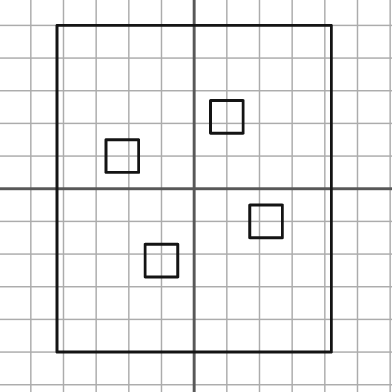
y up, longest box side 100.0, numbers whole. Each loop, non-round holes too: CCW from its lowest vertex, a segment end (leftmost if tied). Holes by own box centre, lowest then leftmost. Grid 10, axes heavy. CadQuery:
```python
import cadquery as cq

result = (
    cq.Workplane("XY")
    .moveTo(-42.0, -50.0)
    .lineTo(42.0, -50.0)
    .lineTo(42.0, 50.0)
    .lineTo(-42.0, 50.0)
    .close()
    .moveTo(-15.0, -27.0)
    .lineTo(-5.0, -27.0)
    .lineTo(-5.0, -17.0)
    .lineTo(-15.0, -17.0)
    .close()
    .moveTo(17.0, -15.0)
    .lineTo(27.0, -15.0)
    .lineTo(27.0, -5.0)
    .lineTo(17.0, -5.0)
    .close()
    .moveTo(-27.0, 5.0)
    .lineTo(-17.0, 5.0)
    .lineTo(-17.0, 15.0)
    .lineTo(-27.0, 15.0)
    .close()
    .moveTo(5.0, 17.0)
    .lineTo(15.0, 17.0)
    .lineTo(15.0, 27.0)
    .lineTo(5.0, 27.0)
    .close()
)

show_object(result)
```